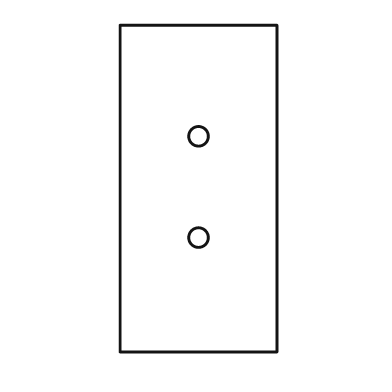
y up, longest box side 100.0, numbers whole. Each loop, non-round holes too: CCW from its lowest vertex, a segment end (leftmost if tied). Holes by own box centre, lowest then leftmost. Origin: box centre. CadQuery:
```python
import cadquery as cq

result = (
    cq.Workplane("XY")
    .moveTo(-24.0, -50.0)
    .lineTo(24.0, -50.0)
    .lineTo(24.0, 50.0)
    .lineTo(-24.0, 50.0)
    .close()
    .moveTo(0.0, -15.0)
    .circle(3.0)
    .moveTo(0.0, 16.0)
    .circle(3.0)
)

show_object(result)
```